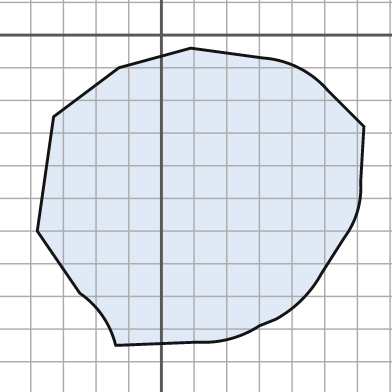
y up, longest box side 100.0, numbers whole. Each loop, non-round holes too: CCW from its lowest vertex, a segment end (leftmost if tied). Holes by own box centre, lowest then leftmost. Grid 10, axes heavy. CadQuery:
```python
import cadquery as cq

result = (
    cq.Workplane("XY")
    .moveTo(-14.0, -95.0)
    .lineTo(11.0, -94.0)
    .threePointArc((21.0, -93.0), (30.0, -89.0))
    .lineTo(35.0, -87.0)
    .threePointArc((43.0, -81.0), (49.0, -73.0))
    .lineTo(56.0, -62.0)
    .threePointArc((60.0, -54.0), (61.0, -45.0))
    .lineTo(62.0, -28.0)
    .lineTo(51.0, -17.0)
    .threePointArc((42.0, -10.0), (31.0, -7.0))
    .lineTo(9.0, -4.0)
    .lineTo(-13.0, -10.0)
    .lineTo(-33.0, -25.0)
    .lineTo(-38.0, -60.0)
    .lineTo(-25.0, -79.0)
    .threePointArc((-18.0, -86.0), (-14.0, -95.0))
    .close()
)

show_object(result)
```